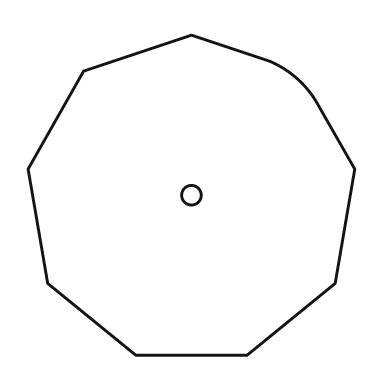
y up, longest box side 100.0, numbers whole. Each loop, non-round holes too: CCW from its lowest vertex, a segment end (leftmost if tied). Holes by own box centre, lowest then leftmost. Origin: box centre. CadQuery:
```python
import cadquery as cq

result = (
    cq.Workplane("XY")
    .moveTo(-17.0, -49.0)
    .lineTo(17.0, -49.0)
    .lineTo(44.0, -27.0)
    .lineTo(50.0, 8.0)
    .lineTo(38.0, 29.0)
    .threePointArc((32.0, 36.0), (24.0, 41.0))
    .lineTo(0.0, 49.0)
    .lineTo(-33.0, 38.0)
    .lineTo(-50.0, 8.0)
    .lineTo(-44.0, -27.0)
    .close()
    .moveTo(0.0, 0.0)
    .circle(3.0)
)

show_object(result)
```